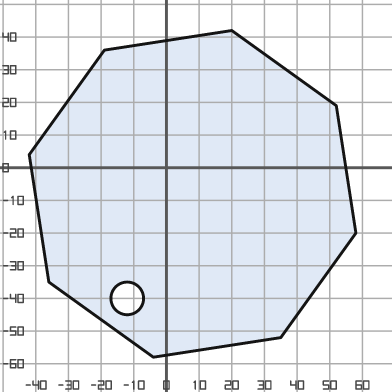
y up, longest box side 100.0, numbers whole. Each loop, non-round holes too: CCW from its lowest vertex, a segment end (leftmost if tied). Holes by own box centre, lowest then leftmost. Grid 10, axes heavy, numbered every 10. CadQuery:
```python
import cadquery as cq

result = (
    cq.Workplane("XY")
    .moveTo(-4.0, -58.0)
    .lineTo(35.0, -52.0)
    .lineTo(58.0, -20.0)
    .lineTo(52.0, 19.0)
    .lineTo(20.0, 42.0)
    .lineTo(-19.0, 36.0)
    .lineTo(-42.0, 4.0)
    .lineTo(-36.0, -35.0)
    .close()
    .moveTo(-12.0, -40.0)
    .circle(5.0)
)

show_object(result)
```